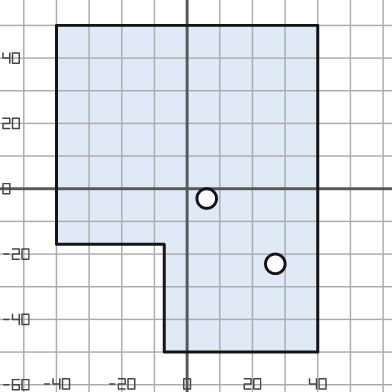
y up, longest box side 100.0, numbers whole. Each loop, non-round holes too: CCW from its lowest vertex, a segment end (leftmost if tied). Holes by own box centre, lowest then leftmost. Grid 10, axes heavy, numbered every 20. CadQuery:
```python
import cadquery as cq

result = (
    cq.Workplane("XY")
    .moveTo(-7.0, -50.0)
    .lineTo(40.0, -50.0)
    .lineTo(40.0, 50.0)
    .lineTo(-40.0, 50.0)
    .lineTo(-40.0, -17.0)
    .lineTo(-7.0, -17.0)
    .close()
    .moveTo(27.0, -23.0)
    .circle(3.0)
    .moveTo(6.0, -3.0)
    .circle(3.0)
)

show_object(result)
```